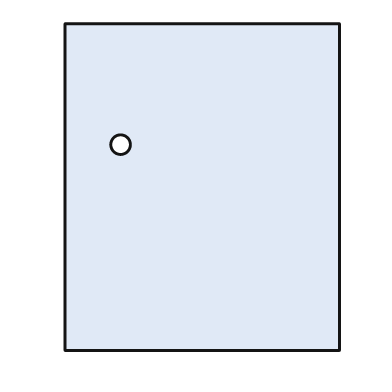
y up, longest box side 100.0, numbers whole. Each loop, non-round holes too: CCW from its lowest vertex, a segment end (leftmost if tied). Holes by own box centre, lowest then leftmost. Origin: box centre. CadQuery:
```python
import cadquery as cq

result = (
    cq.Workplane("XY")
    .moveTo(-42.0, -50.0)
    .lineTo(42.0, -50.0)
    .lineTo(42.0, 50.0)
    .lineTo(-42.0, 50.0)
    .close()
    .moveTo(-25.0, 13.0)
    .circle(3.0)
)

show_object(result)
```